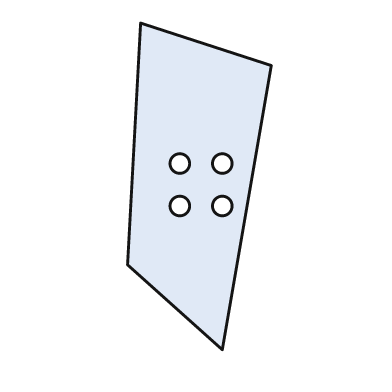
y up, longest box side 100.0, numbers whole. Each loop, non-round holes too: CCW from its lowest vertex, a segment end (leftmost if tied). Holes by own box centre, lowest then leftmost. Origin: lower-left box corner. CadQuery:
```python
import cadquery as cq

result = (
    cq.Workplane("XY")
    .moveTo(29.0, 0.0)
    .lineTo(44.0, 87.0)
    .lineTo(4.0, 100.0)
    .lineTo(0.0, 26.0)
    .close()
    .moveTo(16.0, 44.0)
    .circle(3.0)
    .moveTo(29.0, 44.0)
    .circle(3.0)
    .moveTo(16.0, 57.0)
    .circle(3.0)
    .moveTo(29.0, 57.0)
    .circle(3.0)
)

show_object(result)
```